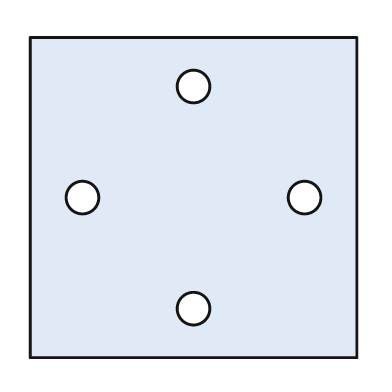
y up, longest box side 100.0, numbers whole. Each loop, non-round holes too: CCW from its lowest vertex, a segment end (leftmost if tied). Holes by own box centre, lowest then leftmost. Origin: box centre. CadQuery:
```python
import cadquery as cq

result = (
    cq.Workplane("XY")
    .moveTo(-50.0, -49.0)
    .lineTo(50.0, -49.0)
    .lineTo(50.0, 49.0)
    .lineTo(-50.0, 49.0)
    .close()
    .moveTo(0.0, -34.0)
    .circle(5.0)
    .moveTo(-34.0, 0.0)
    .circle(5.0)
    .moveTo(34.0, 0.0)
    .circle(5.0)
    .moveTo(0.0, 34.0)
    .circle(5.0)
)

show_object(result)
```